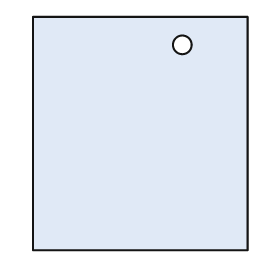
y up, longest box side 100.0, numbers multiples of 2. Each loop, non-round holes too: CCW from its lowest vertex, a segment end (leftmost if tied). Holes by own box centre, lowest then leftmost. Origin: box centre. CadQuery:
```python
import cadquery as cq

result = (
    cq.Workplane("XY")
    .moveTo(-46.0, -50.0)
    .lineTo(46.0, -50.0)
    .lineTo(46.0, 50.0)
    .lineTo(-46.0, 50.0)
    .close()
    .moveTo(18.0, 38.0)
    .circle(4.0)
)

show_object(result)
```